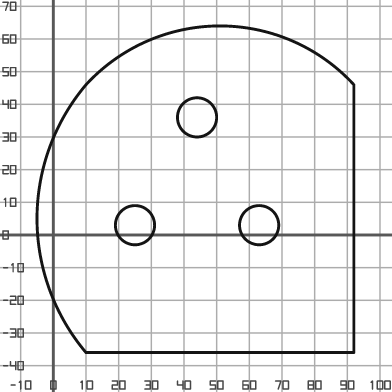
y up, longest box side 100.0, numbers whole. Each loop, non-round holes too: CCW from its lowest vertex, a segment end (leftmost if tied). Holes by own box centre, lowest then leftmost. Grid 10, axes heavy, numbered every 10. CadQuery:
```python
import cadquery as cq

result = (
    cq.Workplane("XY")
    .moveTo(10.0, -36.0)
    .lineTo(92.0, -36.0)
    .lineTo(92.0, 46.0)
    .threePointArc((51.0, 64.0), (10.0, 46.0))
    .threePointArc((-5.0, 5.0), (10.0, -36.0))
    .close()
    .moveTo(25.0, 3.0)
    .circle(6.0)
    .moveTo(63.0, 3.0)
    .circle(6.0)
    .moveTo(44.0, 36.0)
    .circle(6.0)
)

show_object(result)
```